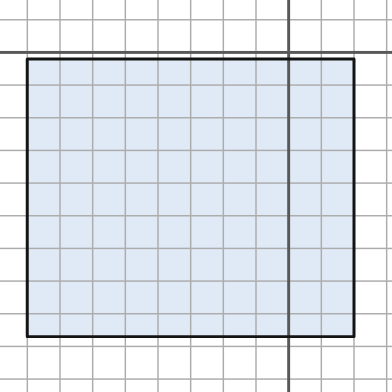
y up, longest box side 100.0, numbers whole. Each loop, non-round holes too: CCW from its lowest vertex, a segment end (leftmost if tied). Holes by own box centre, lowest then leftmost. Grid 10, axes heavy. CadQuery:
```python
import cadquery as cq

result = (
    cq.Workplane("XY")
    .moveTo(-80.0, -87.0)
    .lineTo(20.0, -87.0)
    .lineTo(20.0, -2.0)
    .lineTo(-80.0, -2.0)
    .close()
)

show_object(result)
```